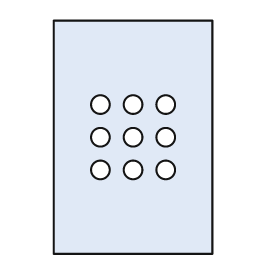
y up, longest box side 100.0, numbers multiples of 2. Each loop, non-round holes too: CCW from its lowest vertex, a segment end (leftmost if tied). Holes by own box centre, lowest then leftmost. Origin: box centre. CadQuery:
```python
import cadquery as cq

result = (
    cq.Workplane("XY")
    .moveTo(-34.0, -50.0)
    .lineTo(34.0, -50.0)
    .lineTo(34.0, 50.0)
    .lineTo(-34.0, 50.0)
    .close()
    .moveTo(-14.0, -14.0)
    .circle(4.0)
    .moveTo(0.0, -14.0)
    .circle(4.0)
    .moveTo(14.0, -14.0)
    .circle(4.0)
    .moveTo(-14.0, 0.0)
    .circle(4.0)
    .moveTo(0.0, 0.0)
    .circle(4.0)
    .moveTo(14.0, 0.0)
    .circle(4.0)
    .moveTo(-14.0, 14.0)
    .circle(4.0)
    .moveTo(0.0, 14.0)
    .circle(4.0)
    .moveTo(14.0, 14.0)
    .circle(4.0)
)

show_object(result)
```